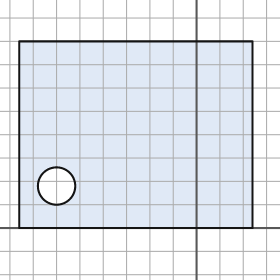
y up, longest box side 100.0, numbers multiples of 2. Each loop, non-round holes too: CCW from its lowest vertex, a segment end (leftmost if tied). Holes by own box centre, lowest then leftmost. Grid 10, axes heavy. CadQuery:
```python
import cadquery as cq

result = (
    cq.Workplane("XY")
    .moveTo(-76.0, 0.0)
    .lineTo(24.0, 0.0)
    .lineTo(24.0, 80.0)
    .lineTo(-76.0, 80.0)
    .close()
    .moveTo(-60.0, 18.0)
    .circle(8.0)
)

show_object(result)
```